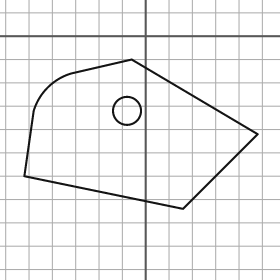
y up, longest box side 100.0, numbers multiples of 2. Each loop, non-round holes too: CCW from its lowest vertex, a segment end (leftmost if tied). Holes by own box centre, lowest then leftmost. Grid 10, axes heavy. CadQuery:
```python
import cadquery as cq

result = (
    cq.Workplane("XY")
    .moveTo(16.0, -74.0)
    .lineTo(48.0, -42.0)
    .lineTo(-6.0, -10.0)
    .lineTo(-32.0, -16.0)
    .threePointArc((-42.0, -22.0), (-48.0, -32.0))
    .lineTo(-52.0, -60.0)
    .close()
    .moveTo(-8.0, -32.0)
    .circle(6.0)
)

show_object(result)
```